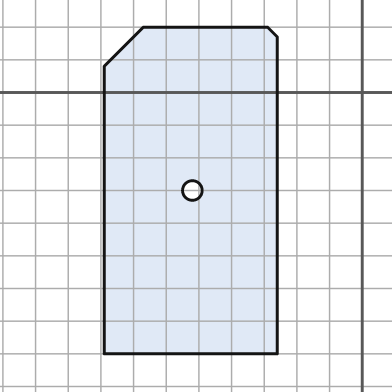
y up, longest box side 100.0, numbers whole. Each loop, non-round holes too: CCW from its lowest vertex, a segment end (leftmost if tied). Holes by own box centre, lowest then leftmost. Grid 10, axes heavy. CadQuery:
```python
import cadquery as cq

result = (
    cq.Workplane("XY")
    .moveTo(-79.0, -80.0)
    .lineTo(-26.0, -80.0)
    .lineTo(-26.0, 17.0)
    .lineTo(-29.0, 20.0)
    .lineTo(-67.0, 20.0)
    .lineTo(-79.0, 8.0)
    .close()
    .moveTo(-52.0, -30.0)
    .circle(3.0)
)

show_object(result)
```